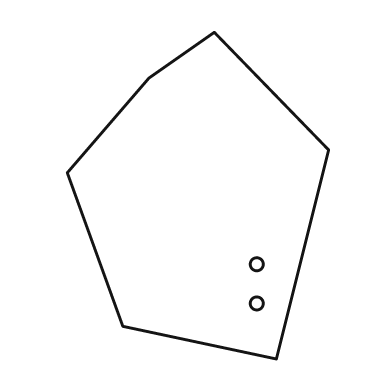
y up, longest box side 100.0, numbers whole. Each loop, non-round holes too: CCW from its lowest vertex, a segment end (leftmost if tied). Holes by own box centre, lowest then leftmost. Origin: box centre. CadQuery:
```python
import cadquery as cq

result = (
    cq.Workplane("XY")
    .moveTo(24.0, -50.0)
    .lineTo(40.0, 14.0)
    .lineTo(5.0, 50.0)
    .lineTo(-15.0, 36.0)
    .lineTo(-40.0, 7.0)
    .lineTo(-23.0, -40.0)
    .close()
    .moveTo(18.0, -33.0)
    .circle(2.0)
    .moveTo(18.0, -21.0)
    .circle(2.0)
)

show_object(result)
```